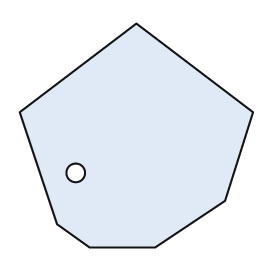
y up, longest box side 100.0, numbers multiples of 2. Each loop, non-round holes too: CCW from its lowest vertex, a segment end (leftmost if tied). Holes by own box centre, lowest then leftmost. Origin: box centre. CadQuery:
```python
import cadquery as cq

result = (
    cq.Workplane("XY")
    .moveTo(-20.0, -48.0)
    .lineTo(8.0, -48.0)
    .lineTo(38.0, -28.0)
    .lineTo(50.0, 10.0)
    .lineTo(0.0, 48.0)
    .lineTo(-50.0, 10.0)
    .lineTo(-34.0, -38.0)
    .close()
    .moveTo(-26.0, -16.0)
    .circle(4.0)
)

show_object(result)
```